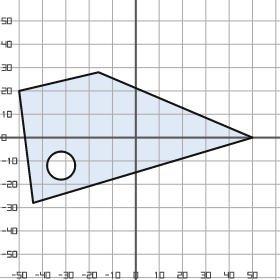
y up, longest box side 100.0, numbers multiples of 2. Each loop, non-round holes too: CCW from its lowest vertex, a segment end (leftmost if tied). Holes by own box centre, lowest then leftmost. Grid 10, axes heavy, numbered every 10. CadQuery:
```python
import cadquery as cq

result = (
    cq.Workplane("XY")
    .moveTo(-44.0, -28.0)
    .lineTo(50.0, 0.0)
    .lineTo(-16.0, 28.0)
    .lineTo(-50.0, 20.0)
    .close()
    .moveTo(-32.0, -12.0)
    .circle(6.0)
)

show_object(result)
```